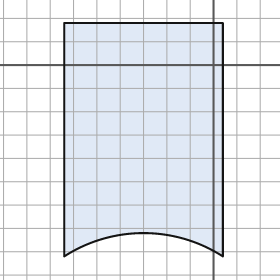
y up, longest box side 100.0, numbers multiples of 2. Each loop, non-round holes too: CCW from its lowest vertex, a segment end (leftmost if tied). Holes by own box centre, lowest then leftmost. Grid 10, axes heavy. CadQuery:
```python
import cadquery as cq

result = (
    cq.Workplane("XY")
    .moveTo(-64.0, -82.0)
    .threePointArc((-30.0, -72.0), (4.0, -82.0))
    .lineTo(4.0, 18.0)
    .lineTo(-64.0, 18.0)
    .close()
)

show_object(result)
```